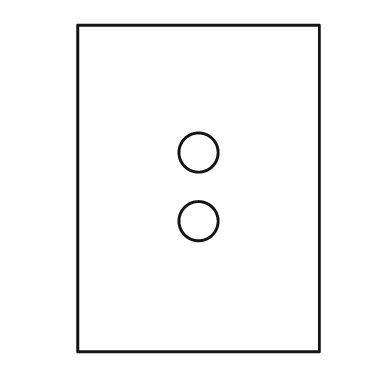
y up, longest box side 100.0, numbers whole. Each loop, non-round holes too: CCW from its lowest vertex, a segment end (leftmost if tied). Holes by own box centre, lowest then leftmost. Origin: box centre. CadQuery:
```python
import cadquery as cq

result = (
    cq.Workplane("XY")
    .moveTo(-37.0, -50.0)
    .lineTo(37.0, -50.0)
    .lineTo(37.0, 50.0)
    .lineTo(-37.0, 50.0)
    .close()
    .moveTo(0.0, -10.0)
    .circle(6.0)
    .moveTo(0.0, 11.0)
    .circle(6.0)
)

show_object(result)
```